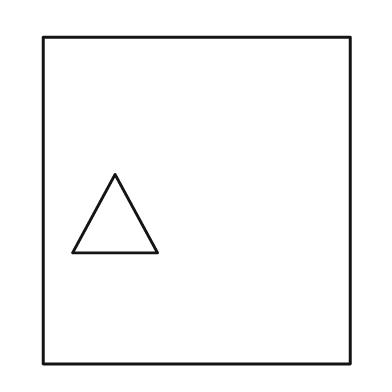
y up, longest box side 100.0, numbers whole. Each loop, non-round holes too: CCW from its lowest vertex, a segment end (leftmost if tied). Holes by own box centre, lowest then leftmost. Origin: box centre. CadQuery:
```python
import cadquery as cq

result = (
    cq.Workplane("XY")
    .moveTo(-47.0, -50.0)
    .lineTo(47.0, -50.0)
    .lineTo(47.0, 50.0)
    .lineTo(-47.0, 50.0)
    .close()
    .moveTo(-38.0, -16.0)
    .lineTo(-12.0, -16.0)
    .lineTo(-25.0, 8.0)
    .close()
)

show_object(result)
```